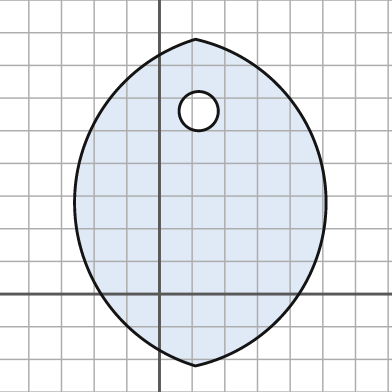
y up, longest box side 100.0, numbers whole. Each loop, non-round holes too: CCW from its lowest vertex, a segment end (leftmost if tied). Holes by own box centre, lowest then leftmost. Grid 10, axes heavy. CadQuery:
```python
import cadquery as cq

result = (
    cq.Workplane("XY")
    .moveTo(11.0, -22.0)
    .threePointArc((51.0, 28.0), (11.0, 78.0))
    .threePointArc((-26.0, 28.0), (11.0, -22.0))
    .close()
    .moveTo(12.0, 56.0)
    .circle(6.0)
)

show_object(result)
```